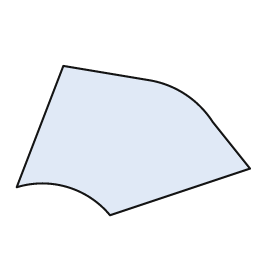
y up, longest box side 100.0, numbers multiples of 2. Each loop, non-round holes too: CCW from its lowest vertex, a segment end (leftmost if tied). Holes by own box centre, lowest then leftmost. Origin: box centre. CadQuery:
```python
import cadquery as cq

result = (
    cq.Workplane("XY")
    .moveTo(-10.0, -32.0)
    .lineTo(50.0, -12.0)
    .lineTo(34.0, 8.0)
    .threePointArc((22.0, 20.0), (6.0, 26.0))
    .lineTo(-30.0, 32.0)
    .lineTo(-50.0, -20.0)
    .threePointArc((-28.0, -20.0), (-10.0, -32.0))
    .close()
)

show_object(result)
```